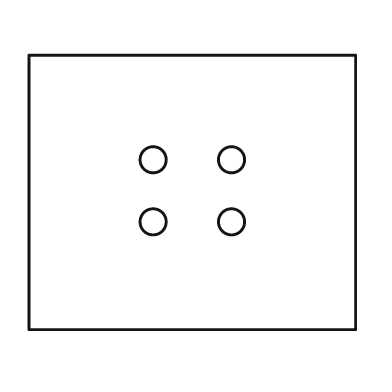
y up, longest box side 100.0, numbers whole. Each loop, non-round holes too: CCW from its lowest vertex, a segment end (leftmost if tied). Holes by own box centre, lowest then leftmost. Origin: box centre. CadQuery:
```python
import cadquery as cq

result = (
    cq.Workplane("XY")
    .moveTo(-50.0, -42.0)
    .lineTo(50.0, -42.0)
    .lineTo(50.0, 42.0)
    .lineTo(-50.0, 42.0)
    .close()
    .moveTo(-12.0, -9.0)
    .circle(4.0)
    .moveTo(12.0, -9.0)
    .circle(4.0)
    .moveTo(-12.0, 10.0)
    .circle(4.0)
    .moveTo(12.0, 10.0)
    .circle(4.0)
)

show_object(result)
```